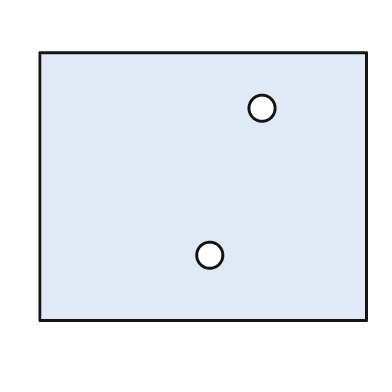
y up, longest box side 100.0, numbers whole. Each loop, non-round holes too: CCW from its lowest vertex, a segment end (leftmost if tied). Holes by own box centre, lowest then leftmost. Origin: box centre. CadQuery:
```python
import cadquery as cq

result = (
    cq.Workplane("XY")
    .moveTo(-50.0, -41.0)
    .lineTo(50.0, -41.0)
    .lineTo(50.0, 41.0)
    .lineTo(-50.0, 41.0)
    .close()
    .moveTo(2.0, -21.0)
    .circle(4.0)
    .moveTo(18.0, 24.0)
    .circle(4.0)
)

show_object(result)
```